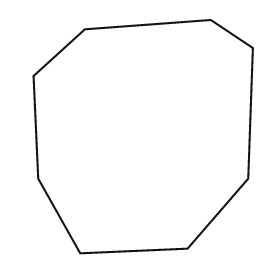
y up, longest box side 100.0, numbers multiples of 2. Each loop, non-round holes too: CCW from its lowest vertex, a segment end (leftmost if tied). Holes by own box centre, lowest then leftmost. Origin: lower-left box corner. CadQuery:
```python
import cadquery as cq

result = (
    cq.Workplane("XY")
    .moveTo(20.0, 0.0)
    .lineTo(66.0, 2.0)
    .lineTo(92.0, 32.0)
    .lineTo(94.0, 88.0)
    .lineTo(76.0, 100.0)
    .lineTo(22.0, 96.0)
    .lineTo(0.0, 76.0)
    .lineTo(2.0, 32.0)
    .close()
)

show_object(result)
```